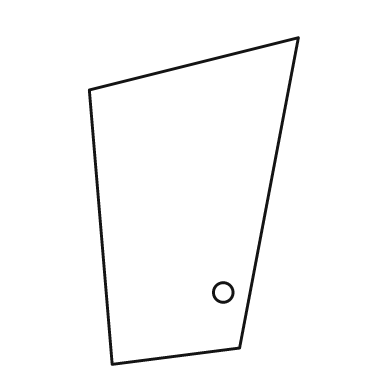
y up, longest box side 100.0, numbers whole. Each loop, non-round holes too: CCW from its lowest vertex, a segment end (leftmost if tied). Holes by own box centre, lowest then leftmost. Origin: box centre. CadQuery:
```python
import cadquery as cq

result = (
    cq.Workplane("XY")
    .moveTo(-25.0, -50.0)
    .lineTo(14.0, -45.0)
    .lineTo(32.0, 50.0)
    .lineTo(-32.0, 34.0)
    .close()
    .moveTo(9.0, -28.0)
    .circle(3.0)
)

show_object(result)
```